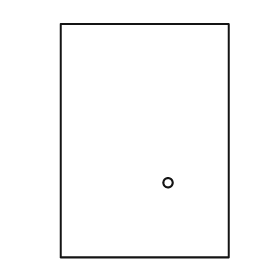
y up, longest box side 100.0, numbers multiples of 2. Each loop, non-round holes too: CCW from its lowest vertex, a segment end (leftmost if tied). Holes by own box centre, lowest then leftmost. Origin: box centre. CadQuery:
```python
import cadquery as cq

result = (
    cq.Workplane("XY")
    .moveTo(-36.0, -50.0)
    .lineTo(36.0, -50.0)
    .lineTo(36.0, 50.0)
    .lineTo(-36.0, 50.0)
    .close()
    .moveTo(10.0, -18.0)
    .circle(2.0)
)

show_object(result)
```